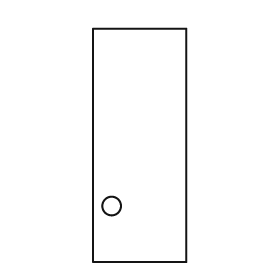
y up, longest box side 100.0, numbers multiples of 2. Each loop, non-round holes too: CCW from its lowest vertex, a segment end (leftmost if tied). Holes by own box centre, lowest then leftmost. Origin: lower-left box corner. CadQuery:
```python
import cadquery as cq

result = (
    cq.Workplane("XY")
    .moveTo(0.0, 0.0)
    .lineTo(40.0, 0.0)
    .lineTo(40.0, 100.0)
    .lineTo(0.0, 100.0)
    .close()
    .moveTo(8.0, 24.0)
    .circle(4.0)
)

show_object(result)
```